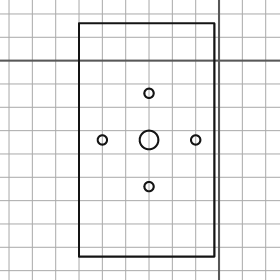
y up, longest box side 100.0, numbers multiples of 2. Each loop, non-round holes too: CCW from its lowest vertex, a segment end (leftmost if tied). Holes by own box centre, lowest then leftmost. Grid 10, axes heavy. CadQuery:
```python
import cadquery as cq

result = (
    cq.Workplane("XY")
    .moveTo(-60.0, -84.0)
    .lineTo(-2.0, -84.0)
    .lineTo(-2.0, 16.0)
    .lineTo(-60.0, 16.0)
    .close()
    .moveTo(-30.0, -54.0)
    .circle(2.0)
    .moveTo(-50.0, -34.0)
    .circle(2.0)
    .moveTo(-30.0, -34.0)
    .circle(4.0)
    .moveTo(-10.0, -34.0)
    .circle(2.0)
    .moveTo(-30.0, -14.0)
    .circle(2.0)
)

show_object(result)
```